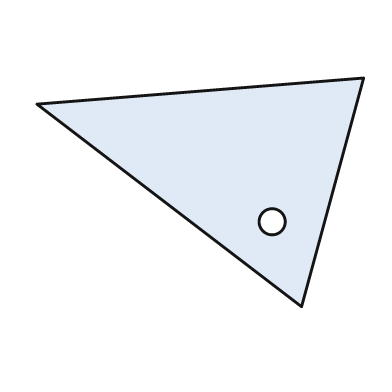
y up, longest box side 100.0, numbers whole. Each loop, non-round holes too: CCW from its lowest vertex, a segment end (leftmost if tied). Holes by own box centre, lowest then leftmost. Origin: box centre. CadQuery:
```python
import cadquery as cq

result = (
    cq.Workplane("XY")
    .moveTo(31.0, -35.0)
    .lineTo(50.0, 35.0)
    .lineTo(-50.0, 27.0)
    .close()
    .moveTo(22.0, -9.0)
    .circle(4.0)
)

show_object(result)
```